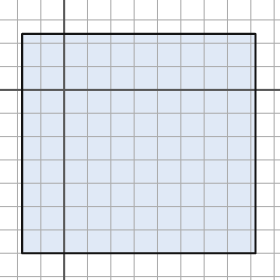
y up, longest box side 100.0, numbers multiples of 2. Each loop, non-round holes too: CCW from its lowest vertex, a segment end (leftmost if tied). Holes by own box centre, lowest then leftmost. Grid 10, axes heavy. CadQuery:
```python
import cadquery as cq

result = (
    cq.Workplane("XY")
    .moveTo(-18.0, -70.0)
    .lineTo(82.0, -70.0)
    .lineTo(82.0, 24.0)
    .lineTo(-18.0, 24.0)
    .close()
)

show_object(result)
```